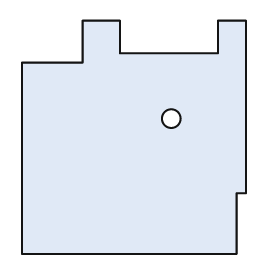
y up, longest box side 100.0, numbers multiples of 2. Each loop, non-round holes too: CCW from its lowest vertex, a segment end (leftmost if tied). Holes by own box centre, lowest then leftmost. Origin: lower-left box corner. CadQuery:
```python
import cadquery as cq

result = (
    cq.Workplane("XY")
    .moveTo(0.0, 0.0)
    .lineTo(92.0, 0.0)
    .lineTo(92.0, 26.0)
    .lineTo(96.0, 26.0)
    .lineTo(96.0, 100.0)
    .lineTo(84.0, 100.0)
    .lineTo(84.0, 86.0)
    .lineTo(42.0, 86.0)
    .lineTo(42.0, 100.0)
    .lineTo(26.0, 100.0)
    .lineTo(26.0, 82.0)
    .lineTo(0.0, 82.0)
    .close()
    .moveTo(64.0, 58.0)
    .circle(4.0)
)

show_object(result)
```